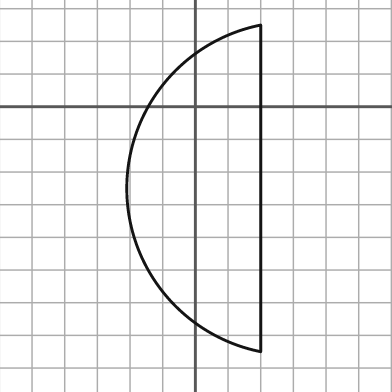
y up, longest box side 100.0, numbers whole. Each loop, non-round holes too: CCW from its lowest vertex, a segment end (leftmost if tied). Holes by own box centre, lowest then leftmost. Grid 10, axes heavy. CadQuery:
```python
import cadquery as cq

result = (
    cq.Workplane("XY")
    .moveTo(20.0, -75.0)
    .lineTo(20.0, 25.0)
    .threePointArc((-21.0, -25.0), (20.0, -75.0))
    .close()
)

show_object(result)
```